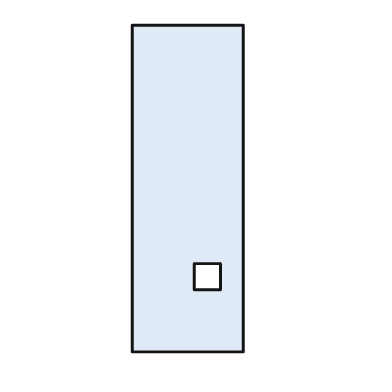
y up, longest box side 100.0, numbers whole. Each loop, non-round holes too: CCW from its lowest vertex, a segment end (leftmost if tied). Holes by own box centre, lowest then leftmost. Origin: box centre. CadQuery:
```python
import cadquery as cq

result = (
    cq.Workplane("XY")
    .moveTo(-17.0, -50.0)
    .lineTo(17.0, -50.0)
    .lineTo(17.0, 50.0)
    .lineTo(-17.0, 50.0)
    .close()
    .moveTo(2.0, -31.0)
    .lineTo(10.0, -31.0)
    .lineTo(10.0, -23.0)
    .lineTo(2.0, -23.0)
    .close()
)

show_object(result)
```